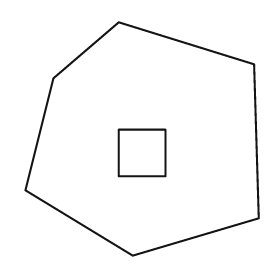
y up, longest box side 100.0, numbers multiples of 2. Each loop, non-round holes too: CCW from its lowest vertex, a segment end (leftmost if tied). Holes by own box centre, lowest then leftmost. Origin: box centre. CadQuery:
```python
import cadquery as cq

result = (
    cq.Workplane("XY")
    .moveTo(-4.0, -50.0)
    .lineTo(50.0, -34.0)
    .lineTo(48.0, 32.0)
    .lineTo(-10.0, 50.0)
    .lineTo(-38.0, 26.0)
    .lineTo(-50.0, -22.0)
    .close()
    .moveTo(-10.0, -16.0)
    .lineTo(10.0, -16.0)
    .lineTo(10.0, 4.0)
    .lineTo(-10.0, 4.0)
    .close()
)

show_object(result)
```